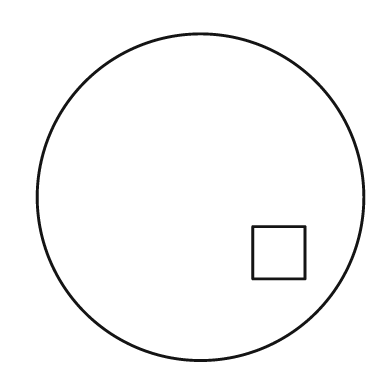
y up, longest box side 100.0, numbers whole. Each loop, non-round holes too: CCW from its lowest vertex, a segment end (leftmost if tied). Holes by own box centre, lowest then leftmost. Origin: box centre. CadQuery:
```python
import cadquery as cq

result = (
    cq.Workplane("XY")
    .moveTo(0.0, 0.0)
    .circle(50.0)
    .moveTo(16.0, -25.0)
    .lineTo(32.0, -25.0)
    .lineTo(32.0, -9.0)
    .lineTo(16.0, -9.0)
    .close()
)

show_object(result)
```